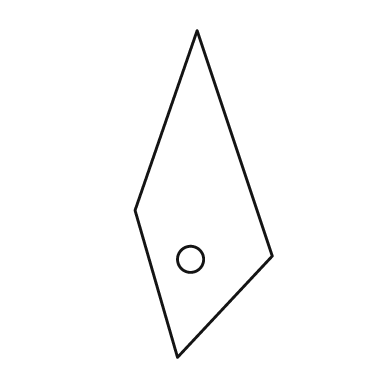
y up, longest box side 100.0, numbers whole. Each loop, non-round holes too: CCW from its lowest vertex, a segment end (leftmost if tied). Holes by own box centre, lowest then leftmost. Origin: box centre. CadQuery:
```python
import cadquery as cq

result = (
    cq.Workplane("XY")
    .moveTo(-8.0, -50.0)
    .lineTo(21.0, -19.0)
    .lineTo(-2.0, 50.0)
    .lineTo(-21.0, -5.0)
    .close()
    .moveTo(-4.0, -20.0)
    .circle(4.0)
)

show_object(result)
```